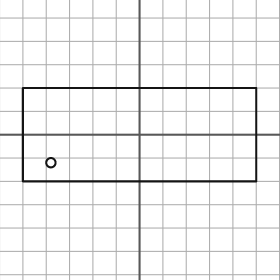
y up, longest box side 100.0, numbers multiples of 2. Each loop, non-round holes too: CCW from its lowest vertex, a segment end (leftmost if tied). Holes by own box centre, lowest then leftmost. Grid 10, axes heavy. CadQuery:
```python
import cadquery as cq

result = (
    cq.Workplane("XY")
    .moveTo(-50.0, -20.0)
    .lineTo(50.0, -20.0)
    .lineTo(50.0, 20.0)
    .lineTo(-50.0, 20.0)
    .close()
    .moveTo(-38.0, -12.0)
    .circle(2.0)
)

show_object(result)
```